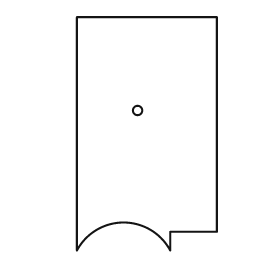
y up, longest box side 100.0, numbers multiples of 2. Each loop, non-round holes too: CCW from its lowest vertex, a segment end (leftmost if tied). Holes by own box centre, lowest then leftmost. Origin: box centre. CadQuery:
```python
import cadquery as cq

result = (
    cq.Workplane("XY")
    .moveTo(-30.0, -50.0)
    .threePointArc((-10.0, -38.0), (10.0, -50.0))
    .lineTo(10.0, -42.0)
    .lineTo(30.0, -42.0)
    .lineTo(30.0, 50.0)
    .lineTo(-30.0, 50.0)
    .close()
    .moveTo(-4.0, 10.0)
    .circle(2.0)
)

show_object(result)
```